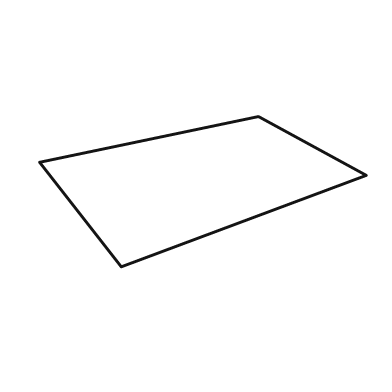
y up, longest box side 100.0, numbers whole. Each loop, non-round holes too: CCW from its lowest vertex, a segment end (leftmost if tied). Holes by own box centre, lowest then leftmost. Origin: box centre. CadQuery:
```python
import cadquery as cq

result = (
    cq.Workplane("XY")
    .moveTo(-25.0, -23.0)
    .lineTo(50.0, 5.0)
    .lineTo(17.0, 23.0)
    .lineTo(-50.0, 9.0)
    .close()
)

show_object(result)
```